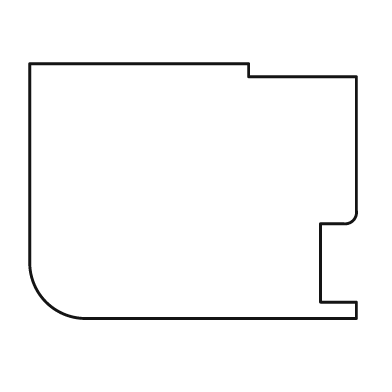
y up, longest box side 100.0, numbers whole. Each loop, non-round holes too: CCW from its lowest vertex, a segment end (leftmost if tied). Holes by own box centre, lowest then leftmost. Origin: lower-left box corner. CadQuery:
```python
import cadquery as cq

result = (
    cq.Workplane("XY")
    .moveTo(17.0, 0.0)
    .lineTo(100.0, 0.0)
    .lineTo(100.0, 5.0)
    .lineTo(89.0, 5.0)
    .lineTo(89.0, 29.0)
    .lineTo(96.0, 29.0)
    .threePointArc((99.0, 30.0), (100.0, 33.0))
    .lineTo(100.0, 74.0)
    .lineTo(67.0, 74.0)
    .lineTo(67.0, 78.0)
    .lineTo(0.0, 78.0)
    .lineTo(0.0, 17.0)
    .threePointArc((5.0, 5.0), (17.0, 0.0))
    .close()
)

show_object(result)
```